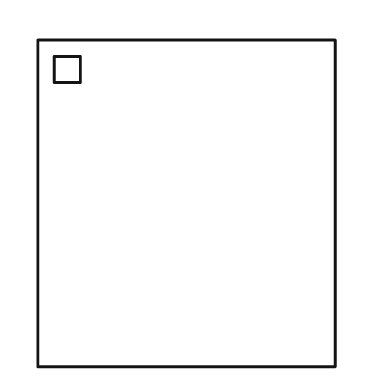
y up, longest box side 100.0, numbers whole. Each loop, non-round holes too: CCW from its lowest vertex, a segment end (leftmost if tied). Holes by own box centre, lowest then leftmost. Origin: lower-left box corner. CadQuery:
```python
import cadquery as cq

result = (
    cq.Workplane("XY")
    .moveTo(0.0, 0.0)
    .lineTo(91.0, 0.0)
    .lineTo(91.0, 100.0)
    .lineTo(0.0, 100.0)
    .close()
    .moveTo(5.0, 87.0)
    .lineTo(13.0, 87.0)
    .lineTo(13.0, 95.0)
    .lineTo(5.0, 95.0)
    .close()
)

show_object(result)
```